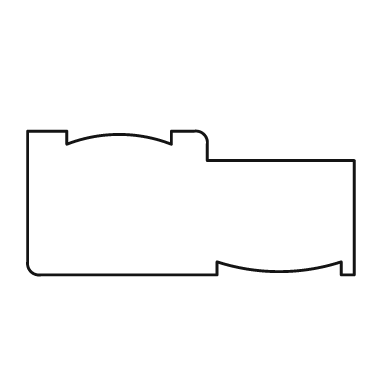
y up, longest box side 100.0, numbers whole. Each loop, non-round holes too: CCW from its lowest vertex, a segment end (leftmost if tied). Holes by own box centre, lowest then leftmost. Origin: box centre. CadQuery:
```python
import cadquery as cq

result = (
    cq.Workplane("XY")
    .moveTo(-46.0, -22.0)
    .lineTo(8.0, -22.0)
    .lineTo(8.0, -18.0)
    .threePointArc((27.0, -21.0), (46.0, -18.0))
    .lineTo(46.0, -22.0)
    .lineTo(50.0, -22.0)
    .lineTo(50.0, 13.0)
    .lineTo(5.0, 13.0)
    .lineTo(5.0, 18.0)
    .threePointArc((4.0, 21.0), (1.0, 22.0))
    .lineTo(-6.0, 22.0)
    .lineTo(-6.0, 18.0)
    .threePointArc((-22.0, 21.0), (-38.0, 18.0))
    .lineTo(-38.0, 22.0)
    .lineTo(-50.0, 22.0)
    .lineTo(-50.0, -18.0)
    .threePointArc((-49.0, -21.0), (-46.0, -22.0))
    .close()
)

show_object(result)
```